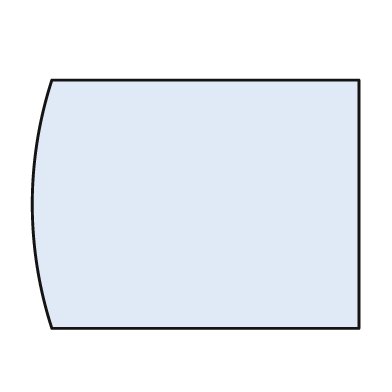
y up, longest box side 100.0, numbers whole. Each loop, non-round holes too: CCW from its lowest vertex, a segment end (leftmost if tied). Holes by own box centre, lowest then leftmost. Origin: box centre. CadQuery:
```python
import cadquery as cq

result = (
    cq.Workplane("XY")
    .moveTo(-44.0, -38.0)
    .lineTo(50.0, -38.0)
    .lineTo(50.0, 38.0)
    .lineTo(-44.0, 38.0)
    .threePointArc((-50.0, 0.0), (-44.0, -38.0))
    .close()
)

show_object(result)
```